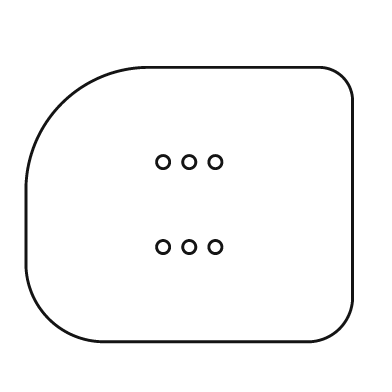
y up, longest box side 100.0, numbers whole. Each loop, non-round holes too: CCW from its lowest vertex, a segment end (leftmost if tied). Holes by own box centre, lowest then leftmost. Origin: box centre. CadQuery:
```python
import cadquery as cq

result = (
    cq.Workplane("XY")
    .moveTo(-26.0, -42.0)
    .lineTo(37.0, -42.0)
    .threePointArc((46.0, -38.0), (50.0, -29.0))
    .lineTo(50.0, 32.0)
    .threePointArc((47.0, 39.0), (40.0, 42.0))
    .lineTo(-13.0, 42.0)
    .threePointArc((-39.0, 31.0), (-50.0, 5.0))
    .lineTo(-50.0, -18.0)
    .threePointArc((-43.0, -35.0), (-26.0, -42.0))
    .close()
    .moveTo(-8.0, -13.0)
    .circle(2.0)
    .moveTo(0.0, -13.0)
    .circle(2.0)
    .moveTo(8.0, -13.0)
    .circle(2.0)
    .moveTo(-8.0, 13.0)
    .circle(2.0)
    .moveTo(0.0, 13.0)
    .circle(2.0)
    .moveTo(8.0, 13.0)
    .circle(2.0)
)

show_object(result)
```